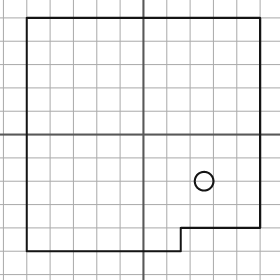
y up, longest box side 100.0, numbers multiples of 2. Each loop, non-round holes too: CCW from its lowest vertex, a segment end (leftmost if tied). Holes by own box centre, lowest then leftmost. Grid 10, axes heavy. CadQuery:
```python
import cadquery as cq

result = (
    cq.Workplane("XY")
    .moveTo(-50.0, -50.0)
    .lineTo(16.0, -50.0)
    .lineTo(16.0, -40.0)
    .lineTo(50.0, -40.0)
    .lineTo(50.0, 50.0)
    .lineTo(-50.0, 50.0)
    .close()
    .moveTo(26.0, -20.0)
    .circle(4.0)
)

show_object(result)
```